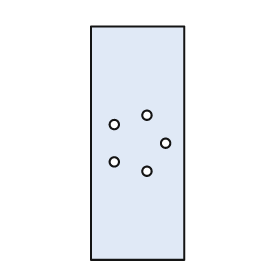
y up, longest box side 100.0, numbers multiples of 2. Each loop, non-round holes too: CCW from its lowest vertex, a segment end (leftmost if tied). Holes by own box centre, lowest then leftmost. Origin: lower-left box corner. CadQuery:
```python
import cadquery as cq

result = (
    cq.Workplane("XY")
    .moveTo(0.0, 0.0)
    .lineTo(40.0, 0.0)
    .lineTo(40.0, 100.0)
    .lineTo(0.0, 100.0)
    .close()
    .moveTo(24.0, 38.0)
    .circle(2.0)
    .moveTo(10.0, 42.0)
    .circle(2.0)
    .moveTo(32.0, 50.0)
    .circle(2.0)
    .moveTo(10.0, 58.0)
    .circle(2.0)
    .moveTo(24.0, 62.0)
    .circle(2.0)
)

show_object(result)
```